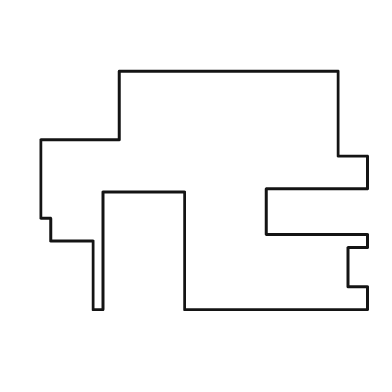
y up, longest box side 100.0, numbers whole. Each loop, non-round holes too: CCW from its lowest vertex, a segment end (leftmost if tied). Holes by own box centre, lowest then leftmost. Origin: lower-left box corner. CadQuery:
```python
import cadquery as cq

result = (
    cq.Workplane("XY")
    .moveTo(16.0, 0.0)
    .lineTo(19.0, 0.0)
    .lineTo(19.0, 36.0)
    .lineTo(44.0, 36.0)
    .lineTo(44.0, 0.0)
    .lineTo(100.0, 0.0)
    .lineTo(100.0, 7.0)
    .lineTo(94.0, 7.0)
    .lineTo(94.0, 19.0)
    .lineTo(100.0, 19.0)
    .lineTo(100.0, 23.0)
    .lineTo(69.0, 23.0)
    .lineTo(69.0, 37.0)
    .lineTo(100.0, 37.0)
    .lineTo(100.0, 47.0)
    .lineTo(91.0, 47.0)
    .lineTo(91.0, 73.0)
    .lineTo(24.0, 73.0)
    .lineTo(24.0, 52.0)
    .lineTo(0.0, 52.0)
    .lineTo(0.0, 28.0)
    .lineTo(3.0, 28.0)
    .lineTo(3.0, 21.0)
    .lineTo(16.0, 21.0)
    .close()
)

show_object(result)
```